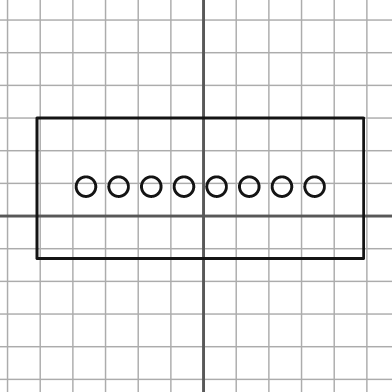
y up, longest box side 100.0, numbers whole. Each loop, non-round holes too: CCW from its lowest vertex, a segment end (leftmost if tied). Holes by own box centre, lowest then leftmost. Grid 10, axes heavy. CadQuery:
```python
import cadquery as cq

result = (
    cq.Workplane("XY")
    .moveTo(-51.0, -13.0)
    .lineTo(49.0, -13.0)
    .lineTo(49.0, 30.0)
    .lineTo(-51.0, 30.0)
    .close()
    .moveTo(-36.0, 9.0)
    .circle(3.0)
    .moveTo(-26.0, 9.0)
    .circle(3.0)
    .moveTo(-16.0, 9.0)
    .circle(3.0)
    .moveTo(-6.0, 9.0)
    .circle(3.0)
    .moveTo(4.0, 9.0)
    .circle(3.0)
    .moveTo(14.0, 9.0)
    .circle(3.0)
    .moveTo(24.0, 9.0)
    .circle(3.0)
    .moveTo(34.0, 9.0)
    .circle(3.0)
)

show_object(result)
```